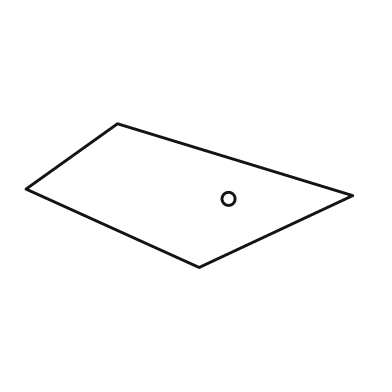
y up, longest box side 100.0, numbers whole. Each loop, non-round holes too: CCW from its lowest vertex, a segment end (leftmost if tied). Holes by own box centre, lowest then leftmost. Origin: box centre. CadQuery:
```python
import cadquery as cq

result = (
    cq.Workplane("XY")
    .moveTo(3.0, -22.0)
    .lineTo(50.0, 0.0)
    .lineTo(-22.0, 22.0)
    .lineTo(-50.0, 2.0)
    .close()
    .moveTo(12.0, -1.0)
    .circle(2.0)
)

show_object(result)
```